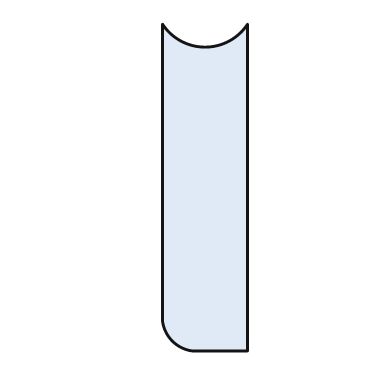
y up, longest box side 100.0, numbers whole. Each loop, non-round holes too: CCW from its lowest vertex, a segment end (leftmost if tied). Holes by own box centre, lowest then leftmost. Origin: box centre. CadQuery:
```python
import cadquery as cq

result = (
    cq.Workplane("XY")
    .moveTo(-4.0, -50.0)
    .lineTo(13.0, -50.0)
    .lineTo(13.0, 50.0)
    .threePointArc((0.0, 43.0), (-13.0, 50.0))
    .lineTo(-13.0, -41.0)
    .threePointArc((-10.0, -47.0), (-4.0, -50.0))
    .close()
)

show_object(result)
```